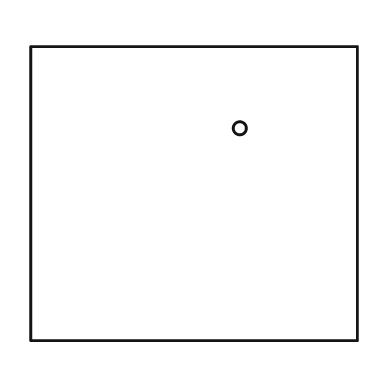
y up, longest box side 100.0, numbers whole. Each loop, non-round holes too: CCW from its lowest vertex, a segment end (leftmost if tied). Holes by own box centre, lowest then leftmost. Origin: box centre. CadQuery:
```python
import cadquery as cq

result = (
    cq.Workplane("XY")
    .moveTo(-50.0, -45.0)
    .lineTo(50.0, -45.0)
    .lineTo(50.0, 45.0)
    .lineTo(-50.0, 45.0)
    .close()
    .moveTo(14.0, 20.0)
    .circle(2.0)
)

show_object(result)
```